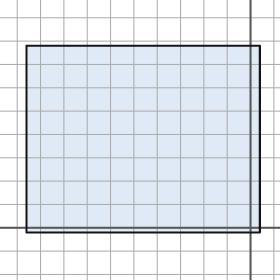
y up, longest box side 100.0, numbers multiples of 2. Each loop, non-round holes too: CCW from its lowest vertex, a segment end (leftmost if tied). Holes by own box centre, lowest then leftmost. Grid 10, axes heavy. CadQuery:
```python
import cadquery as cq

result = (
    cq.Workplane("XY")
    .moveTo(-96.0, -2.0)
    .lineTo(4.0, -2.0)
    .lineTo(4.0, 78.0)
    .lineTo(-96.0, 78.0)
    .close()
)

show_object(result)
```